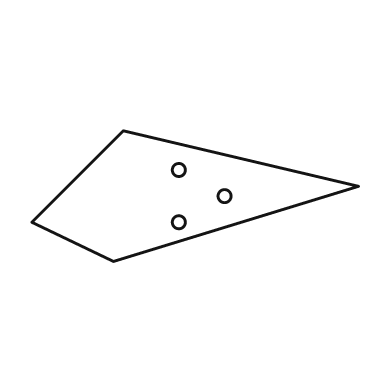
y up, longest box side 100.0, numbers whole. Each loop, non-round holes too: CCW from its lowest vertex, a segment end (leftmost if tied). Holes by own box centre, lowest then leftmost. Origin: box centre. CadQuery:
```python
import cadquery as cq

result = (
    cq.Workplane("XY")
    .moveTo(-25.0, -20.0)
    .lineTo(50.0, 3.0)
    .lineTo(-22.0, 20.0)
    .lineTo(-50.0, -8.0)
    .close()
    .moveTo(-5.0, -8.0)
    .circle(2.0)
    .moveTo(9.0, 0.0)
    .circle(2.0)
    .moveTo(-5.0, 8.0)
    .circle(2.0)
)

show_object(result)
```